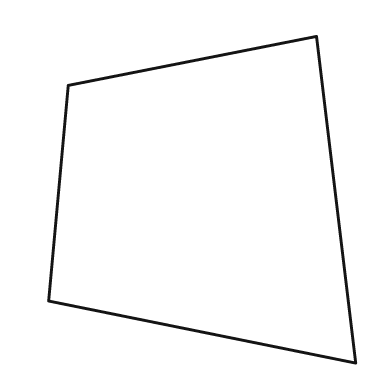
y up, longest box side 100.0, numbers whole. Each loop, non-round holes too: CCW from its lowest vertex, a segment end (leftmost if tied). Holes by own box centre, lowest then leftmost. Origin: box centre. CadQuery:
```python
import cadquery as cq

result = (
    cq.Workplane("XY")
    .moveTo(47.0, -50.0)
    .lineTo(35.0, 50.0)
    .lineTo(-41.0, 35.0)
    .lineTo(-47.0, -31.0)
    .close()
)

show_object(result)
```